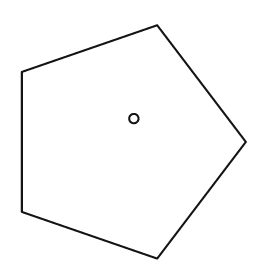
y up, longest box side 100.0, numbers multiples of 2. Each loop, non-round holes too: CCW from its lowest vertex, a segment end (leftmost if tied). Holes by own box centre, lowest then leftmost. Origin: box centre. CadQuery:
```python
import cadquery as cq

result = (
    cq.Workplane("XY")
    .moveTo(10.0, -50.0)
    .lineTo(48.0, 0.0)
    .lineTo(10.0, 50.0)
    .lineTo(-48.0, 30.0)
    .lineTo(-48.0, -30.0)
    .close()
    .moveTo(0.0, 10.0)
    .circle(2.0)
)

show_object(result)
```